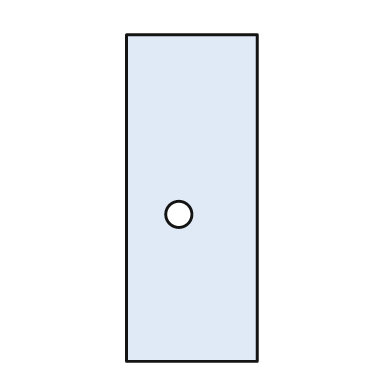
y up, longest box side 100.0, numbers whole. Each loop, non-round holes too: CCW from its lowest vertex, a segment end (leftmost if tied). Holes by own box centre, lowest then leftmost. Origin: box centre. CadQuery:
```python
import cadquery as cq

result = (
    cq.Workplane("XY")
    .moveTo(-20.0, -50.0)
    .lineTo(20.0, -50.0)
    .lineTo(20.0, 50.0)
    .lineTo(-20.0, 50.0)
    .close()
    .moveTo(-4.0, -5.0)
    .circle(4.0)
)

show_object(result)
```